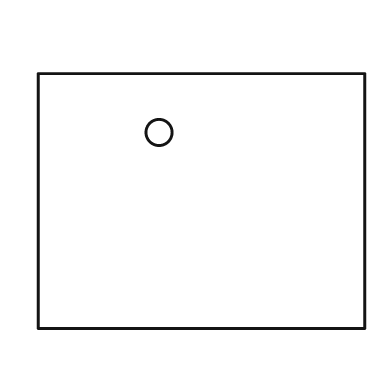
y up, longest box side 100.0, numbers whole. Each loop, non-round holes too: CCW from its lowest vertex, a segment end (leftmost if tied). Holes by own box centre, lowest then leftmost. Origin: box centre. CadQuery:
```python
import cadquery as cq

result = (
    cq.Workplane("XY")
    .moveTo(-50.0, -39.0)
    .lineTo(50.0, -39.0)
    .lineTo(50.0, 39.0)
    .lineTo(-50.0, 39.0)
    .close()
    .moveTo(-13.0, 21.0)
    .circle(4.0)
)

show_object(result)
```